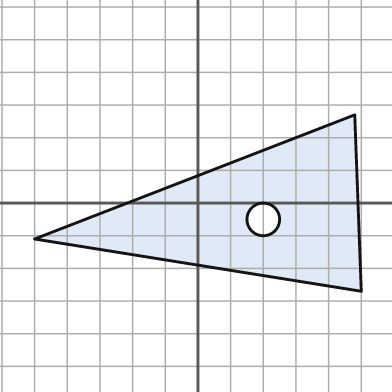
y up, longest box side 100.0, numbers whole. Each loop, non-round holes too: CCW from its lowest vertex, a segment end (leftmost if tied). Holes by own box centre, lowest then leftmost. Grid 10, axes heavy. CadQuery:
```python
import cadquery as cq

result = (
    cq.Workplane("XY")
    .moveTo(50.0, -27.0)
    .lineTo(48.0, 27.0)
    .lineTo(-50.0, -11.0)
    .close()
    .moveTo(20.0, -5.0)
    .circle(5.0)
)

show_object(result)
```